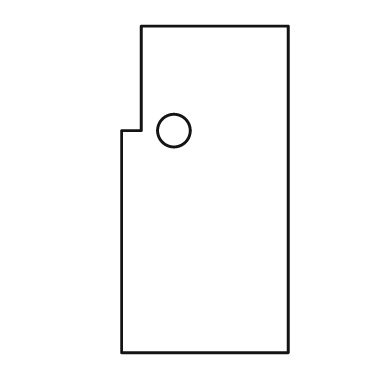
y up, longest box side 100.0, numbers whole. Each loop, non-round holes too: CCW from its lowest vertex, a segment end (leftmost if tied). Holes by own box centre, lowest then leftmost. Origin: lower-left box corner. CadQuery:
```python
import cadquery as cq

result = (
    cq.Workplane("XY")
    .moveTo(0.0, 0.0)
    .lineTo(51.0, 0.0)
    .lineTo(51.0, 100.0)
    .lineTo(6.0, 100.0)
    .lineTo(6.0, 68.0)
    .lineTo(0.0, 68.0)
    .close()
    .moveTo(16.0, 68.0)
    .circle(5.0)
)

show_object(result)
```